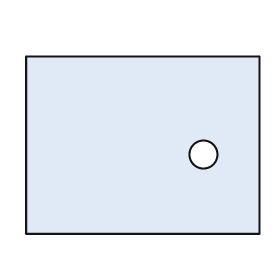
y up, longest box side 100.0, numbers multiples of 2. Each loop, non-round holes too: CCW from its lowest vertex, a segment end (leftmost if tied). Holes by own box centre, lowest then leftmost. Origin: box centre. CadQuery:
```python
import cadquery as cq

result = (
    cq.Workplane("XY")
    .moveTo(-50.0, -38.0)
    .lineTo(50.0, -38.0)
    .lineTo(50.0, 38.0)
    .lineTo(-50.0, 38.0)
    .close()
    .moveTo(26.0, -4.0)
    .circle(6.0)
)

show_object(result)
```